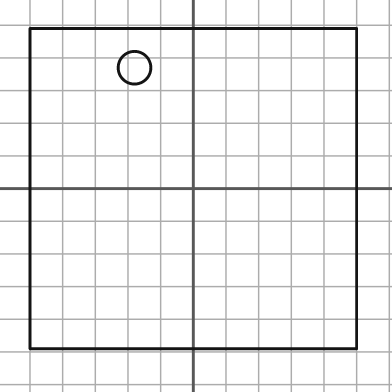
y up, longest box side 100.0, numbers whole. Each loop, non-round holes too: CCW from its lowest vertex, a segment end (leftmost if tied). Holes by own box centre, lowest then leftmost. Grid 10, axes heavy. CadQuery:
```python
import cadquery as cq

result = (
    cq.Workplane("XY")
    .moveTo(-50.0, -49.0)
    .lineTo(50.0, -49.0)
    .lineTo(50.0, 49.0)
    .lineTo(-50.0, 49.0)
    .close()
    .moveTo(-18.0, 37.0)
    .circle(5.0)
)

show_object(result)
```